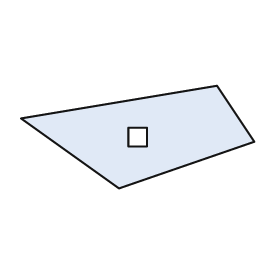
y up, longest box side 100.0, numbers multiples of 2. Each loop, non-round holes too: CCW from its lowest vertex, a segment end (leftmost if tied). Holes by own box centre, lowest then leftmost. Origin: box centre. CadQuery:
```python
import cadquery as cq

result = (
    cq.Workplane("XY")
    .moveTo(-8.0, -22.0)
    .lineTo(50.0, -2.0)
    .lineTo(34.0, 22.0)
    .lineTo(-50.0, 8.0)
    .close()
    .moveTo(-4.0, -4.0)
    .lineTo(4.0, -4.0)
    .lineTo(4.0, 4.0)
    .lineTo(-4.0, 4.0)
    .close()
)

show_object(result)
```